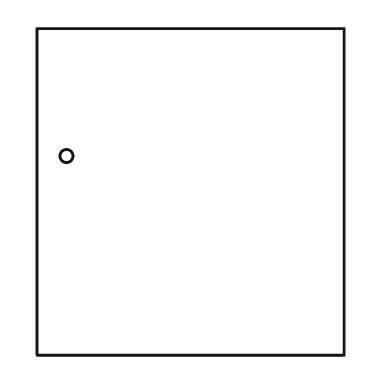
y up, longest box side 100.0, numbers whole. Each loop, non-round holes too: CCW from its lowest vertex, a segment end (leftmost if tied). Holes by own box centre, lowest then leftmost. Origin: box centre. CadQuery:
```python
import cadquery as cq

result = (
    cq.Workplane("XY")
    .moveTo(-47.0, -50.0)
    .lineTo(47.0, -50.0)
    .lineTo(47.0, 50.0)
    .lineTo(-47.0, 50.0)
    .close()
    .moveTo(-38.0, 11.0)
    .circle(2.0)
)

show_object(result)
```